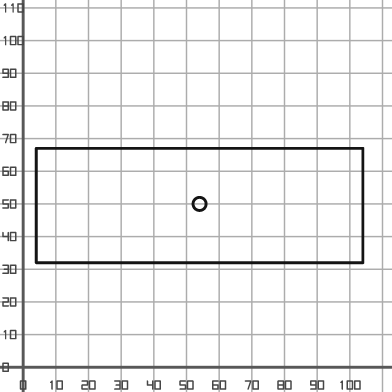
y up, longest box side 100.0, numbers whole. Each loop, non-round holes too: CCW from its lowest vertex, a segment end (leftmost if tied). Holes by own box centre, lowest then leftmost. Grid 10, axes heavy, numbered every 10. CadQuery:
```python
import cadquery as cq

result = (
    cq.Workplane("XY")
    .moveTo(4.0, 32.0)
    .lineTo(104.0, 32.0)
    .lineTo(104.0, 67.0)
    .lineTo(4.0, 67.0)
    .close()
    .moveTo(54.0, 50.0)
    .circle(2.0)
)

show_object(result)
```